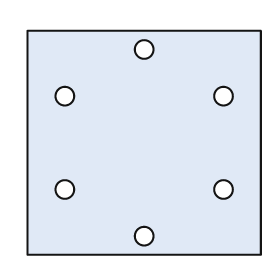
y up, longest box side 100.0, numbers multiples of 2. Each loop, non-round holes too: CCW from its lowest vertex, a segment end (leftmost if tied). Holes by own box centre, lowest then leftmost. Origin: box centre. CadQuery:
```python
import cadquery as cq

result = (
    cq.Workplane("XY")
    .moveTo(-50.0, -48.0)
    .lineTo(50.0, -48.0)
    .lineTo(50.0, 48.0)
    .lineTo(-50.0, 48.0)
    .close()
    .moveTo(0.0, -40.0)
    .circle(4.0)
    .moveTo(-34.0, -20.0)
    .circle(4.0)
    .moveTo(34.0, -20.0)
    .circle(4.0)
    .moveTo(-34.0, 20.0)
    .circle(4.0)
    .moveTo(34.0, 20.0)
    .circle(4.0)
    .moveTo(0.0, 40.0)
    .circle(4.0)
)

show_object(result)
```